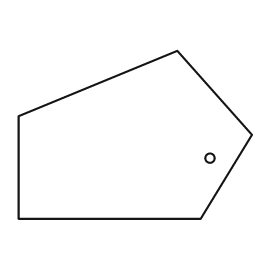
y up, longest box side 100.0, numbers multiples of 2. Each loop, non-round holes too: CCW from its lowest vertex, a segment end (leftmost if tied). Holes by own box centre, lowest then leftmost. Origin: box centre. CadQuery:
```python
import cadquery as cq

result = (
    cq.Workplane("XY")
    .moveTo(-50.0, -36.0)
    .lineTo(28.0, -36.0)
    .lineTo(50.0, 0.0)
    .lineTo(18.0, 36.0)
    .lineTo(-50.0, 8.0)
    .close()
    .moveTo(32.0, -10.0)
    .circle(2.0)
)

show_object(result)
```